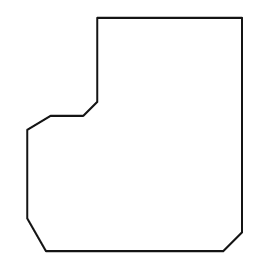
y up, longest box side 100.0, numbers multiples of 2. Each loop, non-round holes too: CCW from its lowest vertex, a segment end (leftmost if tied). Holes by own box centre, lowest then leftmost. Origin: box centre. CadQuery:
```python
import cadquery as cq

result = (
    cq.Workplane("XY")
    .moveTo(-38.0, -50.0)
    .lineTo(38.0, -50.0)
    .lineTo(46.0, -42.0)
    .lineTo(46.0, 50.0)
    .lineTo(-16.0, 50.0)
    .lineTo(-16.0, 14.0)
    .lineTo(-22.0, 8.0)
    .lineTo(-36.0, 8.0)
    .lineTo(-46.0, 2.0)
    .lineTo(-46.0, -36.0)
    .close()
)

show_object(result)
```